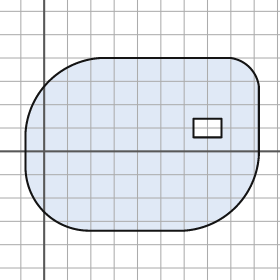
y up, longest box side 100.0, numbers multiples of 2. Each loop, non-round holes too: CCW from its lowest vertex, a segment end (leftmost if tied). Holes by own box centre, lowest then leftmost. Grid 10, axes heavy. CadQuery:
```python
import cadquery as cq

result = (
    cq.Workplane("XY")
    .moveTo(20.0, -34.0)
    .lineTo(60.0, -34.0)
    .threePointArc((82.0, -24.0), (92.0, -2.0))
    .lineTo(92.0, 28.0)
    .threePointArc((88.0, 36.0), (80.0, 40.0))
    .lineTo(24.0, 40.0)
    .threePointArc((2.0, 30.0), (-8.0, 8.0))
    .lineTo(-8.0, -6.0)
    .threePointArc((0.0, -26.0), (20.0, -34.0))
    .close()
    .moveTo(64.0, 6.0)
    .lineTo(76.0, 6.0)
    .lineTo(76.0, 14.0)
    .lineTo(64.0, 14.0)
    .close()
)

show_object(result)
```